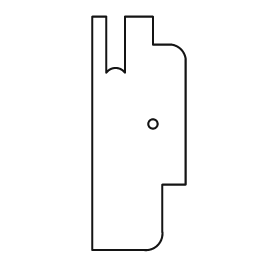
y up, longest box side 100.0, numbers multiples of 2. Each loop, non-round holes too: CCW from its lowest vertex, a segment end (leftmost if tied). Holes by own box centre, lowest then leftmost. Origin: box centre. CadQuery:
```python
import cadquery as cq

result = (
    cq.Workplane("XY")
    .moveTo(-20.0, -50.0)
    .lineTo(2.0, -50.0)
    .threePointArc((8.0, -48.0), (10.0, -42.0))
    .lineTo(10.0, -22.0)
    .lineTo(20.0, -22.0)
    .lineTo(20.0, 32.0)
    .threePointArc((18.0, 36.0), (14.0, 38.0))
    .lineTo(6.0, 38.0)
    .lineTo(6.0, 50.0)
    .lineTo(-6.0, 50.0)
    .lineTo(-6.0, 26.0)
    .threePointArc((-10.0, 28.0), (-14.0, 26.0))
    .lineTo(-14.0, 50.0)
    .lineTo(-20.0, 50.0)
    .close()
    .moveTo(6.0, 4.0)
    .circle(2.0)
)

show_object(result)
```